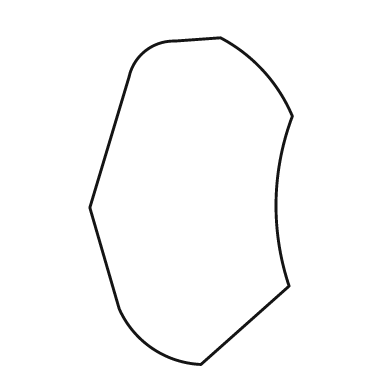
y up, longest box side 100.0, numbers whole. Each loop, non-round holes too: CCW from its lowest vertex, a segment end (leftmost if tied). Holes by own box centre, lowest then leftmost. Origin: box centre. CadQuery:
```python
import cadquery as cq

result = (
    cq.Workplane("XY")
    .moveTo(3.0, -50.0)
    .lineTo(30.0, -26.0)
    .threePointArc((26.0, 0.0), (31.0, 26.0))
    .threePointArc((22.0, 40.0), (9.0, 50.0))
    .lineTo(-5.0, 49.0)
    .threePointArc((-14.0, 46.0), (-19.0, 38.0))
    .lineTo(-31.0, -2.0)
    .lineTo(-22.0, -33.0)
    .threePointArc((-12.0, -45.0), (3.0, -50.0))
    .close()
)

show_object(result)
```